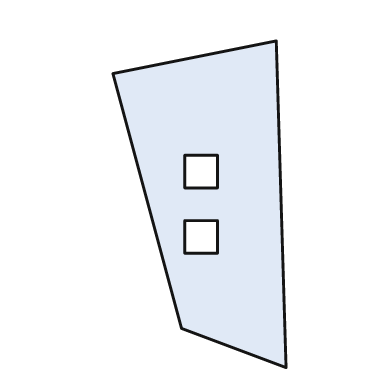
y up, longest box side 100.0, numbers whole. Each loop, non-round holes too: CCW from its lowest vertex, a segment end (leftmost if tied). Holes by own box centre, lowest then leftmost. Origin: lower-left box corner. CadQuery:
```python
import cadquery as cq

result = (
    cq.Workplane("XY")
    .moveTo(53.0, 0.0)
    .lineTo(50.0, 100.0)
    .lineTo(0.0, 90.0)
    .lineTo(21.0, 12.0)
    .close()
    .moveTo(22.0, 35.0)
    .lineTo(32.0, 35.0)
    .lineTo(32.0, 45.0)
    .lineTo(22.0, 45.0)
    .close()
    .moveTo(22.0, 55.0)
    .lineTo(32.0, 55.0)
    .lineTo(32.0, 65.0)
    .lineTo(22.0, 65.0)
    .close()
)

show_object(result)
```